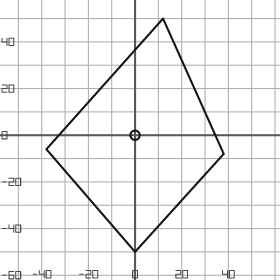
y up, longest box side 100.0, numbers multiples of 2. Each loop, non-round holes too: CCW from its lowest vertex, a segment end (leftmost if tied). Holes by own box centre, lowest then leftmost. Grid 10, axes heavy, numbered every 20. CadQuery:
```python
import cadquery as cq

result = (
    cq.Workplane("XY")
    .moveTo(0.0, -50.0)
    .lineTo(38.0, -8.0)
    .lineTo(12.0, 50.0)
    .lineTo(-38.0, -6.0)
    .close()
    .moveTo(0.0, 0.0)
    .circle(2.0)
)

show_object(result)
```